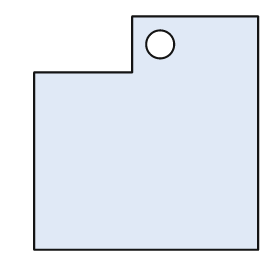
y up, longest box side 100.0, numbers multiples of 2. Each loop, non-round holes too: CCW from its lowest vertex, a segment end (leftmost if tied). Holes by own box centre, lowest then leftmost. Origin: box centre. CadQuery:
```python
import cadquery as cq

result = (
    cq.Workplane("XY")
    .moveTo(-48.0, -50.0)
    .lineTo(48.0, -50.0)
    .lineTo(48.0, 50.0)
    .lineTo(-6.0, 50.0)
    .lineTo(-6.0, 26.0)
    .lineTo(-48.0, 26.0)
    .close()
    .moveTo(6.0, 38.0)
    .circle(6.0)
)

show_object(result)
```